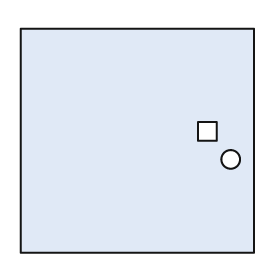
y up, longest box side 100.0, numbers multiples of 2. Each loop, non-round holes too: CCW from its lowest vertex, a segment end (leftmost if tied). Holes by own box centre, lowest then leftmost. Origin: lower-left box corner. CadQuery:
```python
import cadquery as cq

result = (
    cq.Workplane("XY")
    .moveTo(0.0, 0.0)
    .lineTo(100.0, 0.0)
    .lineTo(100.0, 96.0)
    .lineTo(0.0, 96.0)
    .close()
    .moveTo(90.0, 40.0)
    .circle(4.0)
    .moveTo(76.0, 48.0)
    .lineTo(84.0, 48.0)
    .lineTo(84.0, 56.0)
    .lineTo(76.0, 56.0)
    .close()
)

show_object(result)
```